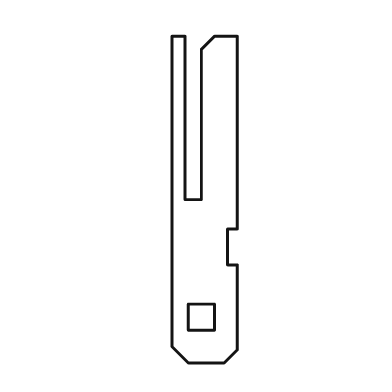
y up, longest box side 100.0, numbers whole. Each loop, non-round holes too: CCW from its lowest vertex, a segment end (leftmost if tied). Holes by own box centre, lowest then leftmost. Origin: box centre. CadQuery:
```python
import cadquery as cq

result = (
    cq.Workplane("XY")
    .moveTo(-5.0, -50.0)
    .lineTo(6.0, -50.0)
    .lineTo(10.0, -46.0)
    .lineTo(10.0, -20.0)
    .lineTo(7.0, -20.0)
    .lineTo(7.0, -9.0)
    .lineTo(10.0, -9.0)
    .lineTo(10.0, 50.0)
    .lineTo(3.0, 50.0)
    .lineTo(-1.0, 46.0)
    .lineTo(-1.0, 0.0)
    .lineTo(-6.0, 0.0)
    .lineTo(-6.0, 50.0)
    .lineTo(-10.0, 50.0)
    .lineTo(-10.0, -45.0)
    .close()
    .moveTo(-5.0, -40.0)
    .lineTo(3.0, -40.0)
    .lineTo(3.0, -32.0)
    .lineTo(-5.0, -32.0)
    .close()
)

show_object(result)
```